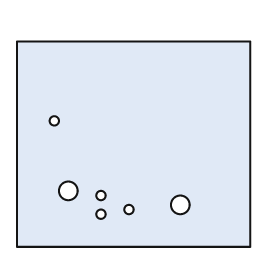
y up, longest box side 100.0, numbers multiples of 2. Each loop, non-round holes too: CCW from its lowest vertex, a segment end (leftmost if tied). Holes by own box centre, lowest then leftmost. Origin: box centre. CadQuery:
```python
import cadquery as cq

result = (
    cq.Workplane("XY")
    .moveTo(-50.0, -44.0)
    .lineTo(50.0, -44.0)
    .lineTo(50.0, 44.0)
    .lineTo(-50.0, 44.0)
    .close()
    .moveTo(-14.0, -30.0)
    .circle(2.0)
    .moveTo(-2.0, -28.0)
    .circle(2.0)
    .moveTo(20.0, -26.0)
    .circle(4.0)
    .moveTo(-14.0, -22.0)
    .circle(2.0)
    .moveTo(-28.0, -20.0)
    .circle(4.0)
    .moveTo(-34.0, 10.0)
    .circle(2.0)
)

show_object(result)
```